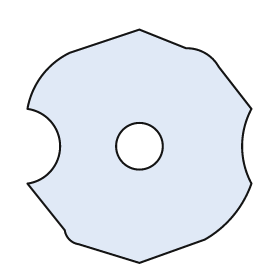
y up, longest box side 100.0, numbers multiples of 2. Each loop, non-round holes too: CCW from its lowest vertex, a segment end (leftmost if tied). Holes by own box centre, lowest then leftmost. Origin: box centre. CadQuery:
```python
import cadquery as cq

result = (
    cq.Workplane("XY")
    .moveTo(0.0, -50.0)
    .lineTo(28.0, -40.0)
    .threePointArc((40.0, -30.0), (48.0, -16.0))
    .threePointArc((44.0, 0.0), (48.0, 16.0))
    .lineTo(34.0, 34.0)
    .threePointArc((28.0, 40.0), (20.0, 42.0))
    .lineTo(0.0, 50.0)
    .lineTo(-30.0, 40.0)
    .threePointArc((-42.0, 30.0), (-48.0, 16.0))
    .threePointArc((-34.0, 0.0), (-48.0, -16.0))
    .lineTo(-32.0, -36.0)
    .threePointArc((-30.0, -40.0), (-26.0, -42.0))
    .close()
    .moveTo(0.0, 0.0)
    .circle(10.0)
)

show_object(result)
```